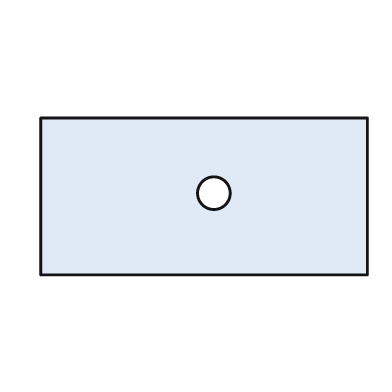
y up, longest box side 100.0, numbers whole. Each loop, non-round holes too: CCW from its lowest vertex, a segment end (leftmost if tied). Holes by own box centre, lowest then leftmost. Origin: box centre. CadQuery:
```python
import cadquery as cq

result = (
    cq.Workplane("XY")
    .moveTo(-50.0, -24.0)
    .lineTo(50.0, -24.0)
    .lineTo(50.0, 24.0)
    .lineTo(-50.0, 24.0)
    .close()
    .moveTo(3.0, 1.0)
    .circle(5.0)
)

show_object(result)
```